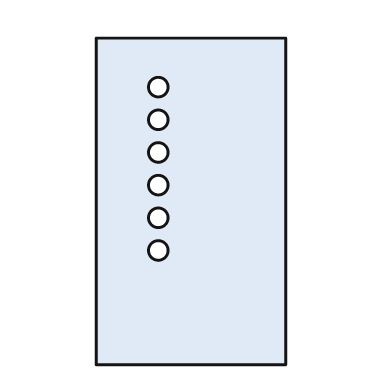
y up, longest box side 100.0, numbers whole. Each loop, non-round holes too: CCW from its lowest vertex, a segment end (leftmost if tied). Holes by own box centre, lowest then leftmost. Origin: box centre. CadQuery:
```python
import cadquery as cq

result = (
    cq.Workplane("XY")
    .moveTo(-29.0, -50.0)
    .lineTo(29.0, -50.0)
    .lineTo(29.0, 50.0)
    .lineTo(-29.0, 50.0)
    .close()
    .moveTo(-10.0, -15.0)
    .circle(3.0)
    .moveTo(-10.0, -5.0)
    .circle(3.0)
    .moveTo(-10.0, 5.0)
    .circle(3.0)
    .moveTo(-10.0, 15.0)
    .circle(3.0)
    .moveTo(-10.0, 25.0)
    .circle(3.0)
    .moveTo(-10.0, 35.0)
    .circle(3.0)
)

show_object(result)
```